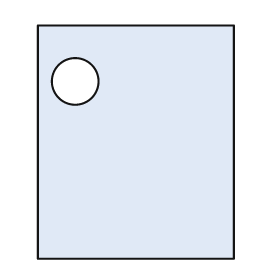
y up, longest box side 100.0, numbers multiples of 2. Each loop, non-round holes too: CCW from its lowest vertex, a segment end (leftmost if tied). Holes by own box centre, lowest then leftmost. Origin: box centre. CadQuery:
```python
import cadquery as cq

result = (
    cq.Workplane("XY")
    .moveTo(-42.0, -50.0)
    .lineTo(42.0, -50.0)
    .lineTo(42.0, 50.0)
    .lineTo(-42.0, 50.0)
    .close()
    .moveTo(-26.0, 26.0)
    .circle(10.0)
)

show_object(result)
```